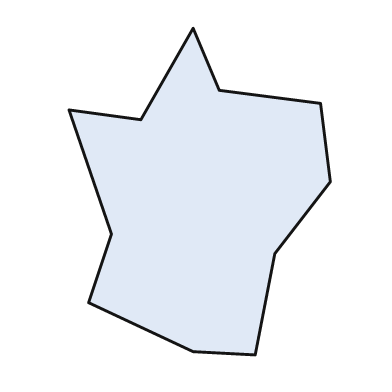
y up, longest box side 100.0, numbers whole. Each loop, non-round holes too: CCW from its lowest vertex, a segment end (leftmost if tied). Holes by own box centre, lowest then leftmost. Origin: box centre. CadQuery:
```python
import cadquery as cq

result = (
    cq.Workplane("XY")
    .moveTo(17.0, -50.0)
    .lineTo(23.0, -19.0)
    .lineTo(40.0, 3.0)
    .lineTo(37.0, 27.0)
    .lineTo(6.0, 31.0)
    .lineTo(-2.0, 50.0)
    .lineTo(-18.0, 22.0)
    .lineTo(-40.0, 25.0)
    .lineTo(-27.0, -13.0)
    .lineTo(-34.0, -34.0)
    .lineTo(-2.0, -49.0)
    .close()
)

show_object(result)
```